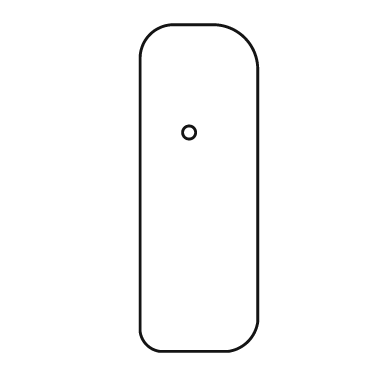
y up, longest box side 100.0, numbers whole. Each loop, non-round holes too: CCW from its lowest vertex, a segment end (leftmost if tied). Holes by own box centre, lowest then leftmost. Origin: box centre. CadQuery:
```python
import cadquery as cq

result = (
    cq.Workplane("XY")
    .moveTo(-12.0, -50.0)
    .lineTo(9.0, -50.0)
    .threePointArc((15.0, -47.0), (18.0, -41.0))
    .lineTo(18.0, 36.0)
    .threePointArc((14.0, 46.0), (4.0, 50.0))
    .lineTo(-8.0, 50.0)
    .threePointArc((-15.0, 47.0), (-18.0, 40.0))
    .lineTo(-18.0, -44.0)
    .threePointArc((-16.0, -48.0), (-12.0, -50.0))
    .close()
    .moveTo(-3.0, 17.0)
    .circle(2.0)
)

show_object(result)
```